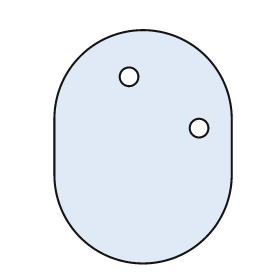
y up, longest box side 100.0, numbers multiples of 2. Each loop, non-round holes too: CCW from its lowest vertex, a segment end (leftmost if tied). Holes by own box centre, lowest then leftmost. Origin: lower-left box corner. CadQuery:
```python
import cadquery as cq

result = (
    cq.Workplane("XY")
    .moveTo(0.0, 38.0)
    .threePointArc((38.0, 0.0), (76.0, 38.0))
    .lineTo(76.0, 62.0)
    .threePointArc((38.0, 100.0), (0.0, 62.0))
    .close()
    .moveTo(62.0, 58.0)
    .circle(4.0)
    .moveTo(32.0, 80.0)
    .circle(4.0)
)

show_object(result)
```